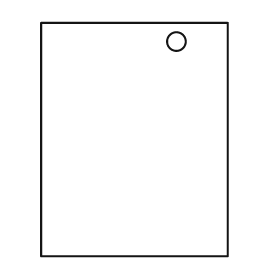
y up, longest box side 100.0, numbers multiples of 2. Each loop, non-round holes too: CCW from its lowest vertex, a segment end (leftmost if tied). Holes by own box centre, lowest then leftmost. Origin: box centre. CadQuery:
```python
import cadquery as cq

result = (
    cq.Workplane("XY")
    .moveTo(-40.0, -50.0)
    .lineTo(40.0, -50.0)
    .lineTo(40.0, 50.0)
    .lineTo(-40.0, 50.0)
    .close()
    .moveTo(18.0, 42.0)
    .circle(4.0)
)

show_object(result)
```